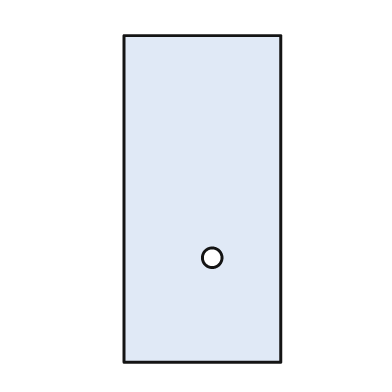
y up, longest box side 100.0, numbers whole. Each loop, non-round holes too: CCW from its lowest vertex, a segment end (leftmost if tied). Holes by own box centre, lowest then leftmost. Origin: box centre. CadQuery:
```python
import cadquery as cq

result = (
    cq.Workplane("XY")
    .moveTo(-24.0, -50.0)
    .lineTo(24.0, -50.0)
    .lineTo(24.0, 50.0)
    .lineTo(-24.0, 50.0)
    .close()
    .moveTo(3.0, -18.0)
    .circle(3.0)
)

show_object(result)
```